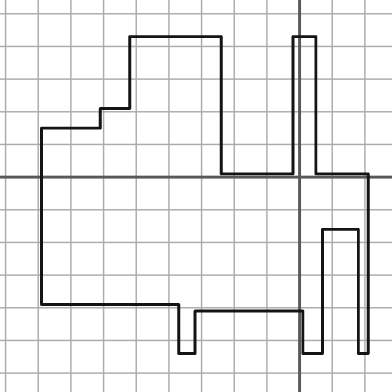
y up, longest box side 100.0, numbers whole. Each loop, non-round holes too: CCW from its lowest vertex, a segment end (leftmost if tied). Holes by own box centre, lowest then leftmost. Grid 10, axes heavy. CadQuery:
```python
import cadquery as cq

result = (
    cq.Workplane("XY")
    .moveTo(-37.0, -54.0)
    .lineTo(-32.0, -54.0)
    .lineTo(-32.0, -41.0)
    .lineTo(1.0, -41.0)
    .lineTo(1.0, -54.0)
    .lineTo(7.0, -54.0)
    .lineTo(7.0, -16.0)
    .lineTo(18.0, -16.0)
    .lineTo(18.0, -54.0)
    .lineTo(21.0, -54.0)
    .lineTo(21.0, 1.0)
    .lineTo(5.0, 1.0)
    .lineTo(5.0, 43.0)
    .lineTo(-2.0, 43.0)
    .lineTo(-2.0, 1.0)
    .lineTo(-24.0, 1.0)
    .lineTo(-24.0, 43.0)
    .lineTo(-52.0, 43.0)
    .lineTo(-52.0, 21.0)
    .lineTo(-61.0, 21.0)
    .lineTo(-61.0, 15.0)
    .lineTo(-79.0, 15.0)
    .lineTo(-79.0, -39.0)
    .lineTo(-37.0, -39.0)
    .close()
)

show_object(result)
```